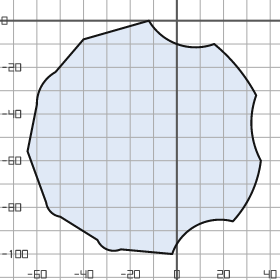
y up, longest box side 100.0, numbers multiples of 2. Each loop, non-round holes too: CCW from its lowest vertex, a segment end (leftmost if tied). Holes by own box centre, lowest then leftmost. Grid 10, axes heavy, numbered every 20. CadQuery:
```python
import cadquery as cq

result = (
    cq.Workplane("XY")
    .moveTo(-2.0, -100.0)
    .threePointArc((8.0, -88.0), (24.0, -86.0))
    .threePointArc((32.0, -74.0), (36.0, -60.0))
    .threePointArc((32.0, -46.0), (34.0, -32.0))
    .threePointArc((26.0, -20.0), (16.0, -10.0))
    .threePointArc((0.0, -10.0), (-12.0, 0.0))
    .lineTo(-40.0, -8.0)
    .lineTo(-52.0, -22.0)
    .threePointArc((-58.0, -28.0), (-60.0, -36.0))
    .lineTo(-64.0, -56.0)
    .lineTo(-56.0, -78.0)
    .threePointArc((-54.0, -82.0), (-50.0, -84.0))
    .lineTo(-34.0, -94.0)
    .threePointArc((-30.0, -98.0), (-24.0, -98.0))
    .close()
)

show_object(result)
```